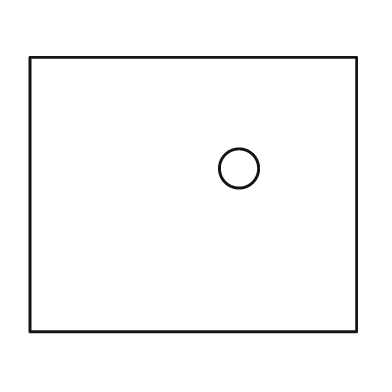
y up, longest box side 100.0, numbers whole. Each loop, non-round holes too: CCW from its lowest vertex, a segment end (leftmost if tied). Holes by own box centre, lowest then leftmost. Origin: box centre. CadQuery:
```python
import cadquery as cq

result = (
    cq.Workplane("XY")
    .moveTo(-50.0, -42.0)
    .lineTo(50.0, -42.0)
    .lineTo(50.0, 42.0)
    .lineTo(-50.0, 42.0)
    .close()
    .moveTo(14.0, 8.0)
    .circle(6.0)
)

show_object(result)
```